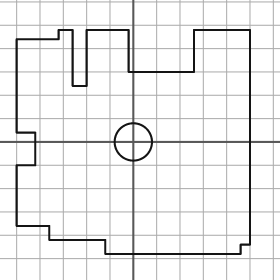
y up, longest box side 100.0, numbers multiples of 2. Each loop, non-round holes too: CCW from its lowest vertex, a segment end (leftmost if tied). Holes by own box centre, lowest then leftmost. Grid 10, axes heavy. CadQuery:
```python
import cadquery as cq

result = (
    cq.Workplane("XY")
    .moveTo(-12.0, -48.0)
    .lineTo(46.0, -48.0)
    .lineTo(46.0, -44.0)
    .lineTo(50.0, -44.0)
    .lineTo(50.0, 48.0)
    .lineTo(26.0, 48.0)
    .lineTo(26.0, 30.0)
    .lineTo(-2.0, 30.0)
    .lineTo(-2.0, 48.0)
    .lineTo(-20.0, 48.0)
    .lineTo(-20.0, 24.0)
    .lineTo(-26.0, 24.0)
    .lineTo(-26.0, 48.0)
    .lineTo(-32.0, 48.0)
    .lineTo(-32.0, 44.0)
    .lineTo(-50.0, 44.0)
    .lineTo(-50.0, 4.0)
    .lineTo(-42.0, 4.0)
    .lineTo(-42.0, -10.0)
    .lineTo(-50.0, -10.0)
    .lineTo(-50.0, -36.0)
    .lineTo(-36.0, -36.0)
    .lineTo(-36.0, -42.0)
    .lineTo(-12.0, -42.0)
    .close()
    .moveTo(0.0, 0.0)
    .circle(8.0)
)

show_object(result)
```